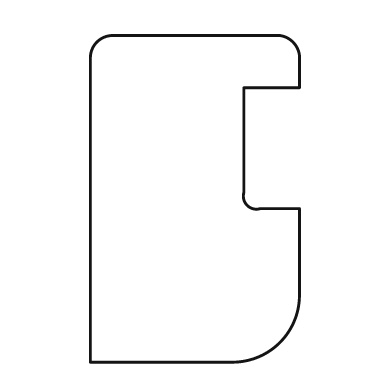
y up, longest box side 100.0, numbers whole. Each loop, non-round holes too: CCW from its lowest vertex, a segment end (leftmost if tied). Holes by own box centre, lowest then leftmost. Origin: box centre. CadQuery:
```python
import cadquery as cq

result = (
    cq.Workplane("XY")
    .moveTo(-32.0, -50.0)
    .lineTo(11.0, -50.0)
    .threePointArc((26.0, -44.0), (32.0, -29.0))
    .lineTo(32.0, -3.0)
    .lineTo(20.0, -3.0)
    .threePointArc((16.0, -2.0), (15.0, 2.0))
    .lineTo(15.0, 34.0)
    .lineTo(32.0, 34.0)
    .lineTo(32.0, 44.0)
    .threePointArc((30.0, 48.0), (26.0, 50.0))
    .lineTo(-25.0, 50.0)
    .threePointArc((-30.0, 48.0), (-32.0, 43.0))
    .close()
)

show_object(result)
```